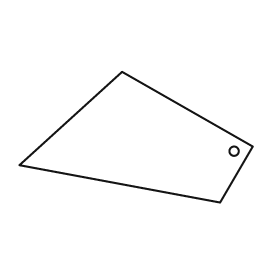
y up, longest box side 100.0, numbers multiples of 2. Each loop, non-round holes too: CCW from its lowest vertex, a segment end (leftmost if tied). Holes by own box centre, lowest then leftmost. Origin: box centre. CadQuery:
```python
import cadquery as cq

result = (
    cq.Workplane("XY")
    .moveTo(36.0, -28.0)
    .lineTo(50.0, -4.0)
    .lineTo(-6.0, 28.0)
    .lineTo(-50.0, -12.0)
    .close()
    .moveTo(42.0, -6.0)
    .circle(2.0)
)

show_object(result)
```